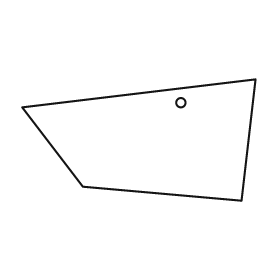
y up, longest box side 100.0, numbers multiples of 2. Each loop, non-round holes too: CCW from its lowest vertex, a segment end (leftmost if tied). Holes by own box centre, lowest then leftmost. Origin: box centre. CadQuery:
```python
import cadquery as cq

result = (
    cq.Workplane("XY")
    .moveTo(44.0, -26.0)
    .lineTo(50.0, 26.0)
    .lineTo(-50.0, 14.0)
    .lineTo(-24.0, -20.0)
    .close()
    .moveTo(18.0, 16.0)
    .circle(2.0)
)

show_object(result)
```